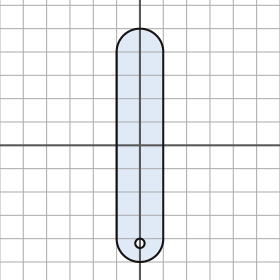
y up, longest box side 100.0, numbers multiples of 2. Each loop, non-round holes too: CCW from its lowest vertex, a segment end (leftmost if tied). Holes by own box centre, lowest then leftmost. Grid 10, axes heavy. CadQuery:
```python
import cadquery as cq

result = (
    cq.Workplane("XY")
    .moveTo(-10.0, -40.0)
    .threePointArc((0.0, -50.0), (10.0, -40.0))
    .lineTo(10.0, 40.0)
    .threePointArc((0.0, 50.0), (-10.0, 40.0))
    .close()
    .moveTo(0.0, -42.0)
    .circle(2.0)
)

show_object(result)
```